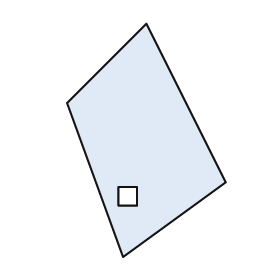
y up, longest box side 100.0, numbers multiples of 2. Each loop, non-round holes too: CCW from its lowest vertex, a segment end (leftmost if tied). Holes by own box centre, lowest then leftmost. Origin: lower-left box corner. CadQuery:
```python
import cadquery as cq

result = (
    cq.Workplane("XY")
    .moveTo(24.0, 0.0)
    .lineTo(68.0, 32.0)
    .lineTo(34.0, 100.0)
    .lineTo(0.0, 66.0)
    .close()
    .moveTo(22.0, 22.0)
    .lineTo(30.0, 22.0)
    .lineTo(30.0, 30.0)
    .lineTo(22.0, 30.0)
    .close()
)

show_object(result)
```